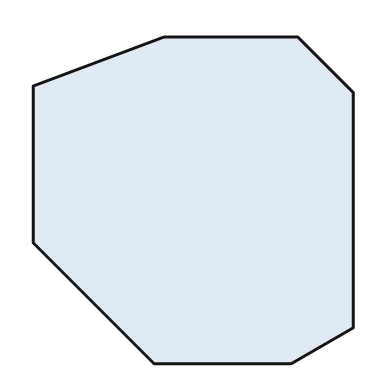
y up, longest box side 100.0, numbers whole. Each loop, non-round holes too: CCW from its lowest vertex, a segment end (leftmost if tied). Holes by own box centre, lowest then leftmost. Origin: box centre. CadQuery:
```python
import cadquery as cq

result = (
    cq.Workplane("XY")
    .moveTo(-12.0, -50.0)
    .lineTo(30.0, -50.0)
    .lineTo(49.0, -39.0)
    .lineTo(49.0, 33.0)
    .lineTo(32.0, 50.0)
    .lineTo(-9.0, 50.0)
    .lineTo(-49.0, 35.0)
    .lineTo(-49.0, -13.0)
    .close()
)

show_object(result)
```